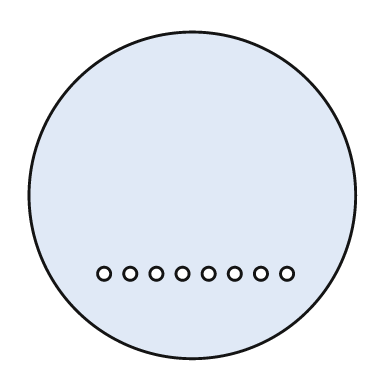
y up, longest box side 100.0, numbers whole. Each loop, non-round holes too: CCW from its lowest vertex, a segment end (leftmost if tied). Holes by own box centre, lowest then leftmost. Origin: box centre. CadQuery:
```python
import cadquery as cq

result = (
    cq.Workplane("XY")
    .moveTo(0.0, 0.0)
    .circle(50.0)
    .moveTo(-27.0, -24.0)
    .circle(2.0)
    .moveTo(-19.0, -24.0)
    .circle(2.0)
    .moveTo(-11.0, -24.0)
    .circle(2.0)
    .moveTo(-3.0, -24.0)
    .circle(2.0)
    .moveTo(5.0, -24.0)
    .circle(2.0)
    .moveTo(13.0, -24.0)
    .circle(2.0)
    .moveTo(21.0, -24.0)
    .circle(2.0)
    .moveTo(29.0, -24.0)
    .circle(2.0)
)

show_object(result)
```